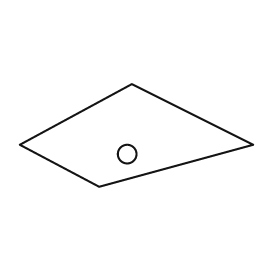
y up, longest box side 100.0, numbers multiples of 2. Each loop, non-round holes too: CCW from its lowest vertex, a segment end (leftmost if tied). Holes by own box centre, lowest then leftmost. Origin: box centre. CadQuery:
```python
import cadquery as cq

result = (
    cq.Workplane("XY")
    .moveTo(-16.0, -22.0)
    .lineTo(50.0, -4.0)
    .lineTo(-2.0, 22.0)
    .lineTo(-50.0, -4.0)
    .close()
    .moveTo(-4.0, -8.0)
    .circle(4.0)
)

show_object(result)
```